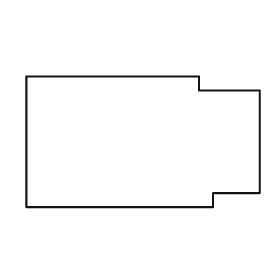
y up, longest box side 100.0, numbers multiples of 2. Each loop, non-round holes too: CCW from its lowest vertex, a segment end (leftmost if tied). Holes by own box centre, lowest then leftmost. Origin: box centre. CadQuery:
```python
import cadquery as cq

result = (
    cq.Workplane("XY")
    .moveTo(-50.0, -28.0)
    .lineTo(30.0, -28.0)
    .lineTo(30.0, -22.0)
    .lineTo(50.0, -22.0)
    .lineTo(50.0, 22.0)
    .lineTo(24.0, 22.0)
    .lineTo(24.0, 28.0)
    .lineTo(-50.0, 28.0)
    .close()
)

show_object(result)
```